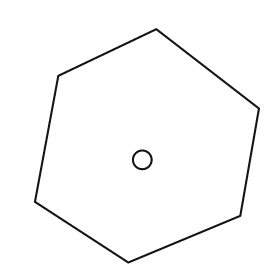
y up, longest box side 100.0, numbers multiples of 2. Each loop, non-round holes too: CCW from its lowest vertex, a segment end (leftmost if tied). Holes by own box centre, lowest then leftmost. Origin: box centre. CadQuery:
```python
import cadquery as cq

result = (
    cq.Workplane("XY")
    .moveTo(-8.0, -50.0)
    .lineTo(40.0, -30.0)
    .lineTo(48.0, 16.0)
    .lineTo(4.0, 50.0)
    .lineTo(-38.0, 30.0)
    .lineTo(-48.0, -24.0)
    .close()
    .moveTo(-2.0, -6.0)
    .circle(4.0)
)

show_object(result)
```